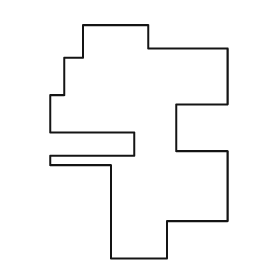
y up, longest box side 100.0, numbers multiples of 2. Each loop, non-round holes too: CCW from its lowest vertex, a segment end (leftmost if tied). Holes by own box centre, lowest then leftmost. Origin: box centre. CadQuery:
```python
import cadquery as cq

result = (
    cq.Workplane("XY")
    .moveTo(-12.0, -50.0)
    .lineTo(12.0, -50.0)
    .lineTo(12.0, -34.0)
    .lineTo(38.0, -34.0)
    .lineTo(38.0, -4.0)
    .lineTo(16.0, -4.0)
    .lineTo(16.0, 16.0)
    .lineTo(38.0, 16.0)
    .lineTo(38.0, 40.0)
    .lineTo(4.0, 40.0)
    .lineTo(4.0, 50.0)
    .lineTo(-24.0, 50.0)
    .lineTo(-24.0, 36.0)
    .lineTo(-32.0, 36.0)
    .lineTo(-32.0, 20.0)
    .lineTo(-38.0, 20.0)
    .lineTo(-38.0, 4.0)
    .lineTo(-2.0, 4.0)
    .lineTo(-2.0, -6.0)
    .lineTo(-38.0, -6.0)
    .lineTo(-38.0, -10.0)
    .lineTo(-12.0, -10.0)
    .close()
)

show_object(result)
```